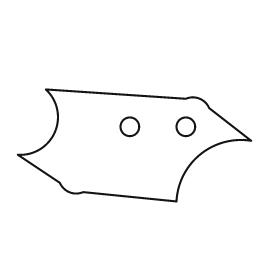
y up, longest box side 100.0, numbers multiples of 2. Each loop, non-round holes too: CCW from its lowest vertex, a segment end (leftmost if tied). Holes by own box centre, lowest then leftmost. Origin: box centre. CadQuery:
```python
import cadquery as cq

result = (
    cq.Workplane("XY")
    .moveTo(18.0, -24.0)
    .threePointArc((28.0, -4.0), (50.0, 2.0))
    .lineTo(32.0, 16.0)
    .threePointArc((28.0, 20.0), (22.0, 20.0))
    .lineTo(-38.0, 24.0)
    .threePointArc((-34.0, 6.0), (-50.0, -4.0))
    .lineTo(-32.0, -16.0)
    .threePointArc((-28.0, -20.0), (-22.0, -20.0))
    .close()
    .moveTo(-2.0, 8.0)
    .circle(4.0)
    .moveTo(22.0, 8.0)
    .circle(4.0)
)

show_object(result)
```